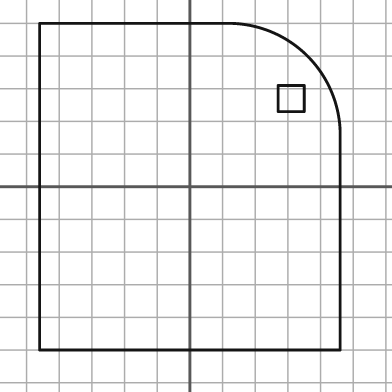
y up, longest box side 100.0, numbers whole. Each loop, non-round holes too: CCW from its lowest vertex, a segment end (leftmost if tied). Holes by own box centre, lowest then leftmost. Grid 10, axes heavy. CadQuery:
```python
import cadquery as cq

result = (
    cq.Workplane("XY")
    .moveTo(-46.0, -50.0)
    .lineTo(46.0, -50.0)
    .lineTo(46.0, 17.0)
    .threePointArc((36.0, 40.0), (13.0, 50.0))
    .lineTo(-46.0, 50.0)
    .close()
    .moveTo(27.0, 23.0)
    .lineTo(35.0, 23.0)
    .lineTo(35.0, 31.0)
    .lineTo(27.0, 31.0)
    .close()
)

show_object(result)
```